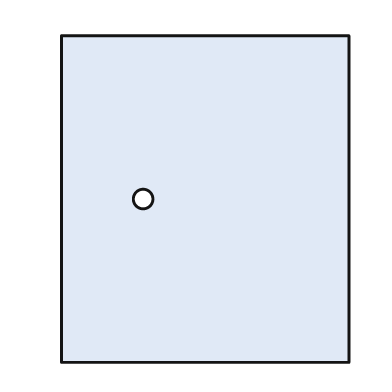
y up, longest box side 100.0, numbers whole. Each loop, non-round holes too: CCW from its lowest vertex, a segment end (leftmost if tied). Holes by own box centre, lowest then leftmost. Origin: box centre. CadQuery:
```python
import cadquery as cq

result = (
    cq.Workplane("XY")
    .moveTo(-44.0, -50.0)
    .lineTo(44.0, -50.0)
    .lineTo(44.0, 50.0)
    .lineTo(-44.0, 50.0)
    .close()
    .moveTo(-19.0, 0.0)
    .circle(3.0)
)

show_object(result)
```